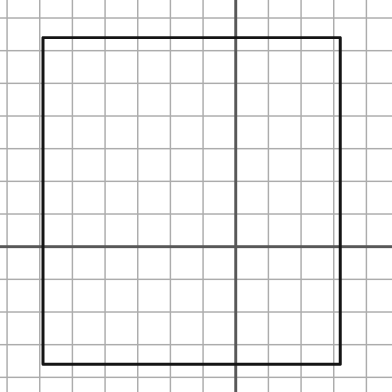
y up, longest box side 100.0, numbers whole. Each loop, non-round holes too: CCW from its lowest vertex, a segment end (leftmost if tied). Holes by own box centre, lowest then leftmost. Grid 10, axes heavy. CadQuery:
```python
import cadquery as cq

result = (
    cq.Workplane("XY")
    .moveTo(-59.0, -36.0)
    .lineTo(32.0, -36.0)
    .lineTo(32.0, 64.0)
    .lineTo(-59.0, 64.0)
    .close()
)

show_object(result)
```